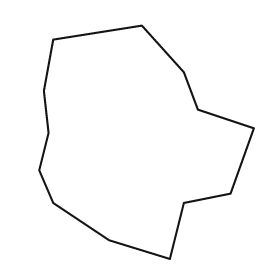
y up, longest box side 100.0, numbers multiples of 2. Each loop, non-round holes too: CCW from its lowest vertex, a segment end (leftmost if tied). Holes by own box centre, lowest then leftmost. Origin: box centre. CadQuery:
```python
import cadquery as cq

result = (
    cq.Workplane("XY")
    .moveTo(10.0, -50.0)
    .lineTo(16.0, -26.0)
    .lineTo(36.0, -22.0)
    .lineTo(46.0, 6.0)
    .lineTo(22.0, 14.0)
    .lineTo(16.0, 30.0)
    .lineTo(-2.0, 50.0)
    .lineTo(-40.0, 44.0)
    .lineTo(-44.0, 22.0)
    .lineTo(-42.0, 4.0)
    .lineTo(-46.0, -12.0)
    .lineTo(-40.0, -26.0)
    .lineTo(-16.0, -42.0)
    .close()
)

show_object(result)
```